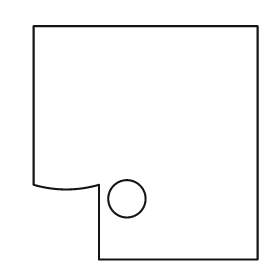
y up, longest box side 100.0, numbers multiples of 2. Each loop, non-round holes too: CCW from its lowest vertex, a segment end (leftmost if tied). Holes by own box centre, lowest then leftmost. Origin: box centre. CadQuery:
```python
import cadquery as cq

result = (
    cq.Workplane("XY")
    .moveTo(-20.0, -50.0)
    .lineTo(48.0, -50.0)
    .lineTo(48.0, 50.0)
    .lineTo(-48.0, 50.0)
    .lineTo(-48.0, -18.0)
    .threePointArc((-34.0, -20.0), (-20.0, -18.0))
    .close()
    .moveTo(-8.0, -24.0)
    .circle(8.0)
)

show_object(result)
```